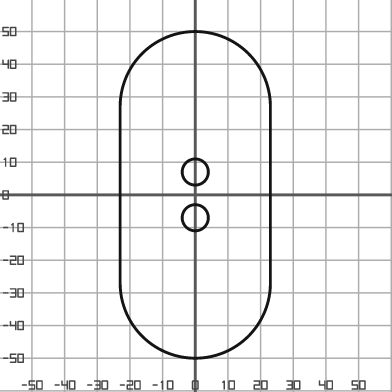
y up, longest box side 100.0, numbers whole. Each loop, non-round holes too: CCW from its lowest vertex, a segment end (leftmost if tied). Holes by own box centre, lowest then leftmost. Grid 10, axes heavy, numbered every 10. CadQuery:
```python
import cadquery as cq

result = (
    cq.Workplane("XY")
    .moveTo(-23.0, -27.0)
    .threePointArc((0.0, -50.0), (23.0, -27.0))
    .lineTo(23.0, 27.0)
    .threePointArc((0.0, 50.0), (-23.0, 27.0))
    .close()
    .moveTo(0.0, -7.0)
    .circle(4.0)
    .moveTo(0.0, 7.0)
    .circle(4.0)
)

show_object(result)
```